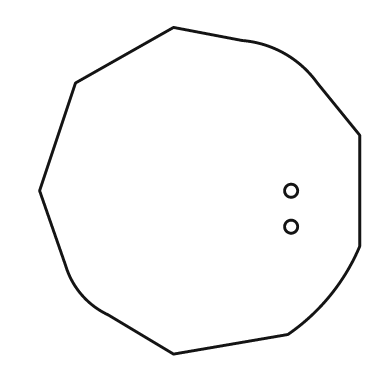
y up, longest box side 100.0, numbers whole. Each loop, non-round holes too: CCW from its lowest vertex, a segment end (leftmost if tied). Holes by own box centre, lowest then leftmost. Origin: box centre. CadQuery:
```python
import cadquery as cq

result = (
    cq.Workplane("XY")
    .moveTo(-8.0, -50.0)
    .lineTo(27.0, -44.0)
    .threePointArc((40.0, -32.0), (49.0, -17.0))
    .lineTo(49.0, 17.0)
    .lineTo(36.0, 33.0)
    .threePointArc((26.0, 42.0), (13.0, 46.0))
    .lineTo(-8.0, 50.0)
    .lineTo(-38.0, 33.0)
    .lineTo(-49.0, 0.0)
    .lineTo(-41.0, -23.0)
    .threePointArc((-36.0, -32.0), (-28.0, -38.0))
    .close()
    .moveTo(28.0, -11.0)
    .circle(2.0)
    .moveTo(28.0, 0.0)
    .circle(2.0)
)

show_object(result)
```